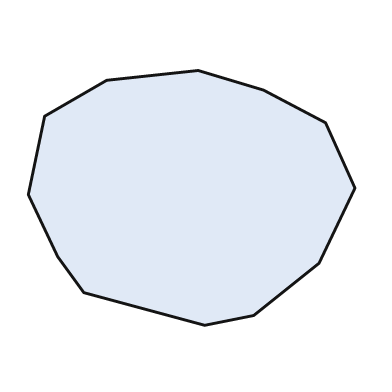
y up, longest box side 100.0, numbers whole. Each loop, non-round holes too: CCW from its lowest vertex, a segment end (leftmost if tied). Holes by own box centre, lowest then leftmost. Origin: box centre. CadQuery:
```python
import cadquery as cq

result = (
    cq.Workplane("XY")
    .moveTo(4.0, -39.0)
    .lineTo(19.0, -36.0)
    .lineTo(39.0, -20.0)
    .lineTo(50.0, 3.0)
    .lineTo(41.0, 23.0)
    .lineTo(22.0, 33.0)
    .lineTo(2.0, 39.0)
    .lineTo(-26.0, 36.0)
    .lineTo(-45.0, 25.0)
    .lineTo(-50.0, 1.0)
    .lineTo(-41.0, -18.0)
    .lineTo(-33.0, -29.0)
    .close()
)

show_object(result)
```